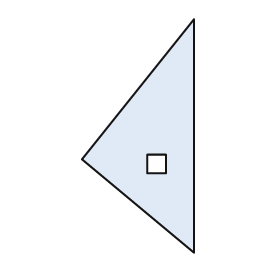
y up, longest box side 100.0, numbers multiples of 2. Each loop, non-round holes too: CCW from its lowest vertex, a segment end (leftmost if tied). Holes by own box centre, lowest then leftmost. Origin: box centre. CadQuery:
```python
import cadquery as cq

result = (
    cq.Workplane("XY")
    .moveTo(24.0, -50.0)
    .lineTo(24.0, 50.0)
    .lineTo(-24.0, -10.0)
    .close()
    .moveTo(4.0, -16.0)
    .lineTo(12.0, -16.0)
    .lineTo(12.0, -8.0)
    .lineTo(4.0, -8.0)
    .close()
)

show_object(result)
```